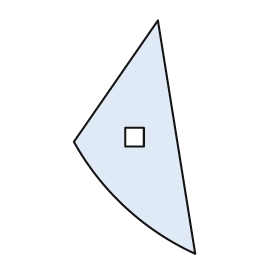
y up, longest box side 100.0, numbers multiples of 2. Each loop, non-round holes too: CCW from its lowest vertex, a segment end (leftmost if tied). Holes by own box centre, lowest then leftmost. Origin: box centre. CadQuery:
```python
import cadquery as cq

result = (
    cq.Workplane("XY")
    .moveTo(26.0, -50.0)
    .lineTo(10.0, 50.0)
    .lineTo(-26.0, -2.0)
    .threePointArc((-4.0, -30.0), (26.0, -50.0))
    .close()
    .moveTo(-4.0, -4.0)
    .lineTo(4.0, -4.0)
    .lineTo(4.0, 4.0)
    .lineTo(-4.0, 4.0)
    .close()
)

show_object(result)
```